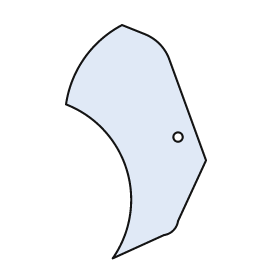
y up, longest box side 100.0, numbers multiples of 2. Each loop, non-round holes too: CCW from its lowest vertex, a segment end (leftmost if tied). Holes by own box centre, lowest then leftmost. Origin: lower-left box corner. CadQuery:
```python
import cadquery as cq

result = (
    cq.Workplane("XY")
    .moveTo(20.0, 0.0)
    .lineTo(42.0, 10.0)
    .threePointArc((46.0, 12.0), (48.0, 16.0))
    .lineTo(60.0, 42.0)
    .lineTo(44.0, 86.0)
    .threePointArc((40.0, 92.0), (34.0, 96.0))
    .lineTo(24.0, 100.0)
    .threePointArc((8.0, 86.0), (0.0, 66.0))
    .threePointArc((26.0, 38.0), (20.0, 0.0))
    .close()
    .moveTo(48.0, 52.0)
    .circle(2.0)
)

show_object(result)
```